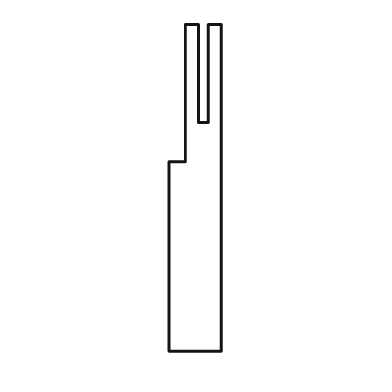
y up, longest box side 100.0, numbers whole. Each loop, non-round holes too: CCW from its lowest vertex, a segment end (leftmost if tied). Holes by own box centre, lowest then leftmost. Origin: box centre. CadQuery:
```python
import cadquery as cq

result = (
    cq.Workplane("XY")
    .moveTo(-8.0, -50.0)
    .lineTo(8.0, -50.0)
    .lineTo(8.0, 50.0)
    .lineTo(4.0, 50.0)
    .lineTo(4.0, 20.0)
    .lineTo(1.0, 20.0)
    .lineTo(1.0, 50.0)
    .lineTo(-3.0, 50.0)
    .lineTo(-3.0, 8.0)
    .lineTo(-8.0, 8.0)
    .close()
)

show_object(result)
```